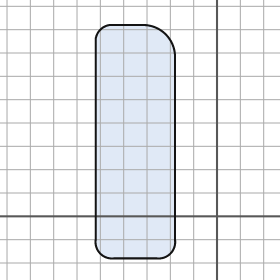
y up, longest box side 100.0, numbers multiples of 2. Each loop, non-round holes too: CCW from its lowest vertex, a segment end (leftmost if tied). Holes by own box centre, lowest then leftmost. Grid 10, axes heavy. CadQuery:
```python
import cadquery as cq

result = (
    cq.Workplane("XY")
    .moveTo(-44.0, -18.0)
    .lineTo(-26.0, -18.0)
    .threePointArc((-20.0, -16.0), (-18.0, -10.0))
    .lineTo(-18.0, 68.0)
    .threePointArc((-22.0, 78.0), (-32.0, 82.0))
    .lineTo(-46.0, 82.0)
    .threePointArc((-50.0, 80.0), (-52.0, 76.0))
    .lineTo(-52.0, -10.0)
    .threePointArc((-50.0, -16.0), (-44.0, -18.0))
    .close()
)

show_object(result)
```